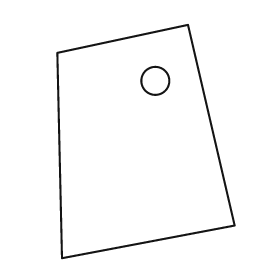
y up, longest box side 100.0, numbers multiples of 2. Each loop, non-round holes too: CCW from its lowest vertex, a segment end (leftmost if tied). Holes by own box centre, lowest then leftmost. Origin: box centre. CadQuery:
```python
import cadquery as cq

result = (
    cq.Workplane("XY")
    .moveTo(-36.0, -50.0)
    .lineTo(38.0, -36.0)
    .lineTo(18.0, 50.0)
    .lineTo(-38.0, 38.0)
    .close()
    .moveTo(4.0, 26.0)
    .circle(6.0)
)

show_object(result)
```